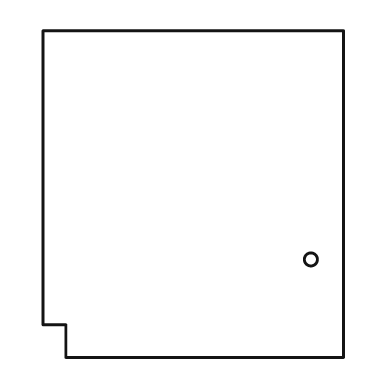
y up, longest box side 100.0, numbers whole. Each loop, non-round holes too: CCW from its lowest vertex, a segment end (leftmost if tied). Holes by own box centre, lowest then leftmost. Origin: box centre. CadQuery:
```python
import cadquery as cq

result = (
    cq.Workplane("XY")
    .moveTo(-39.0, -50.0)
    .lineTo(46.0, -50.0)
    .lineTo(46.0, 50.0)
    .lineTo(-46.0, 50.0)
    .lineTo(-46.0, -40.0)
    .lineTo(-39.0, -40.0)
    .close()
    .moveTo(36.0, -20.0)
    .circle(2.0)
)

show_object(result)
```